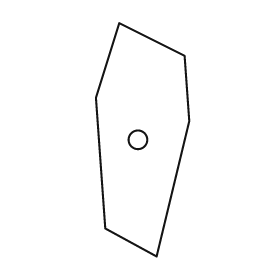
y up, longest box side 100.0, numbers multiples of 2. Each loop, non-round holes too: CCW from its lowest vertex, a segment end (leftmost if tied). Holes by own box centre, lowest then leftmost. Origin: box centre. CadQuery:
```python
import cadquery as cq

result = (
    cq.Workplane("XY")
    .moveTo(6.0, -50.0)
    .lineTo(20.0, 8.0)
    .lineTo(18.0, 36.0)
    .lineTo(-10.0, 50.0)
    .lineTo(-20.0, 18.0)
    .lineTo(-16.0, -38.0)
    .close()
    .moveTo(-2.0, 0.0)
    .circle(4.0)
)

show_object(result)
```